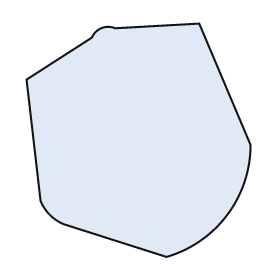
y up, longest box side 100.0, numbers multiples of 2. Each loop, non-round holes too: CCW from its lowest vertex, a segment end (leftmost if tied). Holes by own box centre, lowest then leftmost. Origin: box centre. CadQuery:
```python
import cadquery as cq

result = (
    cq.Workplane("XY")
    .moveTo(12.0, -50.0)
    .threePointArc((38.0, -32.0), (48.0, -2.0))
    .lineTo(26.0, 50.0)
    .lineTo(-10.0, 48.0)
    .threePointArc((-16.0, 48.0), (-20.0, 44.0))
    .lineTo(-48.0, 26.0)
    .lineTo(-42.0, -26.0)
    .threePointArc((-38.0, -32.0), (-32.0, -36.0))
    .close()
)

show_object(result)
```